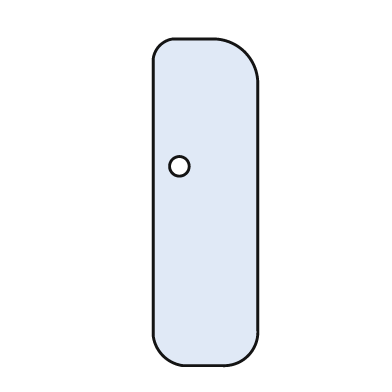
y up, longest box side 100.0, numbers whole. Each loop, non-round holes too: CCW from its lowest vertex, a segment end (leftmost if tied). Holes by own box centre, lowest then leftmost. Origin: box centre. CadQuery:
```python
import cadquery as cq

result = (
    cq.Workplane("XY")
    .moveTo(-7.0, -50.0)
    .lineTo(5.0, -50.0)
    .threePointArc((13.0, -47.0), (16.0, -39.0))
    .lineTo(16.0, 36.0)
    .threePointArc((12.0, 46.0), (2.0, 50.0))
    .lineTo(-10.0, 50.0)
    .threePointArc((-14.0, 48.0), (-16.0, 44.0))
    .lineTo(-16.0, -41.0)
    .threePointArc((-13.0, -47.0), (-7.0, -50.0))
    .close()
    .moveTo(-8.0, 11.0)
    .circle(3.0)
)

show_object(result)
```